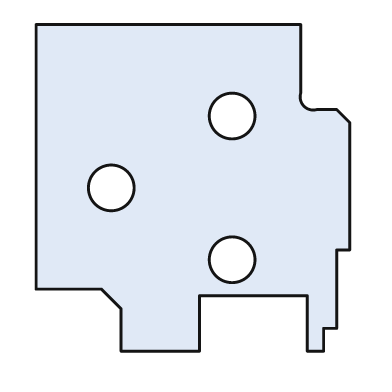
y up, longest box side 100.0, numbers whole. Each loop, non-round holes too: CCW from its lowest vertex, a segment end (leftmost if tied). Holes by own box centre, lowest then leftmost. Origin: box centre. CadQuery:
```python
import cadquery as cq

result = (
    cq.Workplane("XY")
    .moveTo(-22.0, -50.0)
    .lineTo(2.0, -50.0)
    .lineTo(2.0, -33.0)
    .lineTo(35.0, -33.0)
    .lineTo(35.0, -50.0)
    .lineTo(40.0, -50.0)
    .lineTo(40.0, -43.0)
    .lineTo(44.0, -43.0)
    .lineTo(44.0, -19.0)
    .lineTo(48.0, -19.0)
    .lineTo(48.0, 20.0)
    .lineTo(44.0, 24.0)
    .lineTo(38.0, 24.0)
    .threePointArc((34.0, 25.0), (33.0, 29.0))
    .lineTo(33.0, 50.0)
    .lineTo(-48.0, 50.0)
    .lineTo(-48.0, -31.0)
    .lineTo(-28.0, -31.0)
    .lineTo(-22.0, -37.0)
    .close()
    .moveTo(12.0, -22.0)
    .circle(7.0)
    .moveTo(-25.0, 0.0)
    .circle(7.0)
    .moveTo(12.0, 22.0)
    .circle(7.0)
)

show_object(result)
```